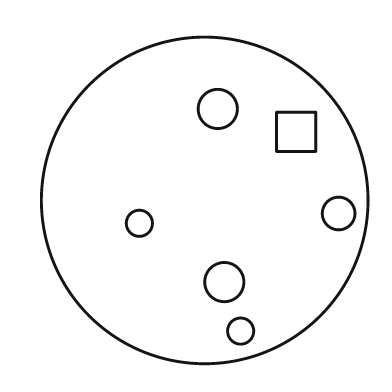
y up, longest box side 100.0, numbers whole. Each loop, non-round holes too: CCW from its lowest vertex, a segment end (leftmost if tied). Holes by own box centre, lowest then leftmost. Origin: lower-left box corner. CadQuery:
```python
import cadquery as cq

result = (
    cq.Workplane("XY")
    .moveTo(50.0, 50.0)
    .circle(50.0)
    .moveTo(61.0, 10.0)
    .circle(4.0)
    .moveTo(56.0, 25.0)
    .circle(6.0)
    .moveTo(30.0, 43.0)
    .circle(4.0)
    .moveTo(91.0, 46.0)
    .circle(5.0)
    .moveTo(72.0, 65.0)
    .lineTo(84.0, 65.0)
    .lineTo(84.0, 77.0)
    .lineTo(72.0, 77.0)
    .close()
    .moveTo(54.0, 78.0)
    .circle(6.0)
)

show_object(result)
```